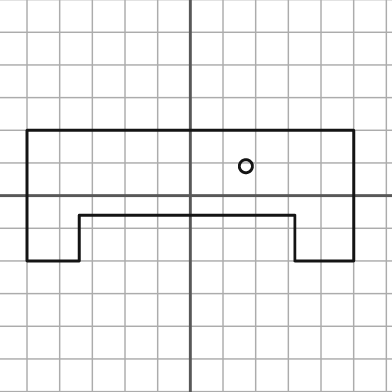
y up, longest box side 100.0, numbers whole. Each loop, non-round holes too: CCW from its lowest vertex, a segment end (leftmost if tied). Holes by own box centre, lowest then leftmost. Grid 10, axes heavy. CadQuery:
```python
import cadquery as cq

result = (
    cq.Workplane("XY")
    .moveTo(-50.0, -20.0)
    .lineTo(-34.0, -20.0)
    .lineTo(-34.0, -6.0)
    .lineTo(32.0, -6.0)
    .lineTo(32.0, -20.0)
    .lineTo(50.0, -20.0)
    .lineTo(50.0, 20.0)
    .lineTo(-50.0, 20.0)
    .close()
    .moveTo(17.0, 9.0)
    .circle(2.0)
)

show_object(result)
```